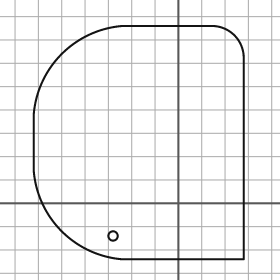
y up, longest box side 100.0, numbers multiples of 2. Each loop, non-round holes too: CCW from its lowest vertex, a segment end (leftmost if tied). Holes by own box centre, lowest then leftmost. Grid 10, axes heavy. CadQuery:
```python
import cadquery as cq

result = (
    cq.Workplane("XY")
    .moveTo(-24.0, -24.0)
    .lineTo(28.0, -24.0)
    .lineTo(28.0, 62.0)
    .threePointArc((24.0, 72.0), (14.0, 76.0))
    .lineTo(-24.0, 76.0)
    .threePointArc((-50.0, 64.0), (-62.0, 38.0))
    .lineTo(-62.0, 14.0)
    .threePointArc((-50.0, -12.0), (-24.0, -24.0))
    .close()
    .moveTo(-28.0, -14.0)
    .circle(2.0)
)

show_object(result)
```